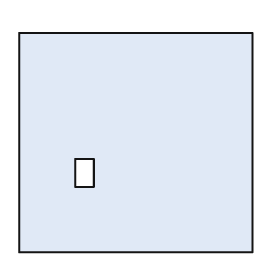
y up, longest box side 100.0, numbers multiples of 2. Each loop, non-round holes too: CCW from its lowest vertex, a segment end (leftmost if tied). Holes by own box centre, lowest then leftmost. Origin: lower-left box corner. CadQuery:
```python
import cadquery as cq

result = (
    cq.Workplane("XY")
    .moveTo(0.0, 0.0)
    .lineTo(100.0, 0.0)
    .lineTo(100.0, 94.0)
    .lineTo(0.0, 94.0)
    .close()
    .moveTo(24.0, 28.0)
    .lineTo(32.0, 28.0)
    .lineTo(32.0, 40.0)
    .lineTo(24.0, 40.0)
    .close()
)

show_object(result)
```